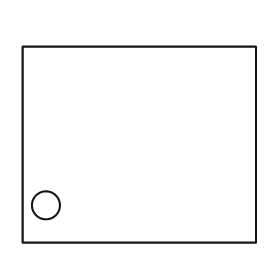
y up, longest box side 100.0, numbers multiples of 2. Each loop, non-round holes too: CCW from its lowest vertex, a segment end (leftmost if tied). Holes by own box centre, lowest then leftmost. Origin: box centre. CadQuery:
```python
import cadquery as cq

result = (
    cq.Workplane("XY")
    .moveTo(-50.0, -42.0)
    .lineTo(50.0, -42.0)
    .lineTo(50.0, 42.0)
    .lineTo(-50.0, 42.0)
    .close()
    .moveTo(-40.0, -26.0)
    .circle(6.0)
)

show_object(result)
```